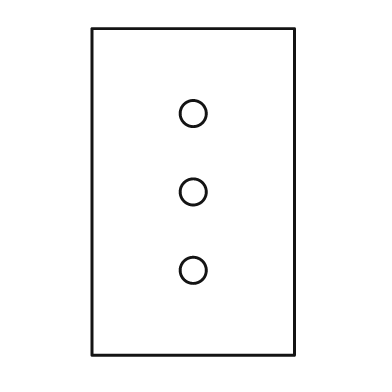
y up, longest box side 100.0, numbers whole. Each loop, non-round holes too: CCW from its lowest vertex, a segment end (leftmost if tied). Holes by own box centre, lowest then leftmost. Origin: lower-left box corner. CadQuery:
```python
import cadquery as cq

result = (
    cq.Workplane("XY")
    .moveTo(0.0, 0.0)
    .lineTo(62.0, 0.0)
    .lineTo(62.0, 100.0)
    .lineTo(0.0, 100.0)
    .close()
    .moveTo(31.0, 26.0)
    .circle(4.0)
    .moveTo(31.0, 50.0)
    .circle(4.0)
    .moveTo(31.0, 74.0)
    .circle(4.0)
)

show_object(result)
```